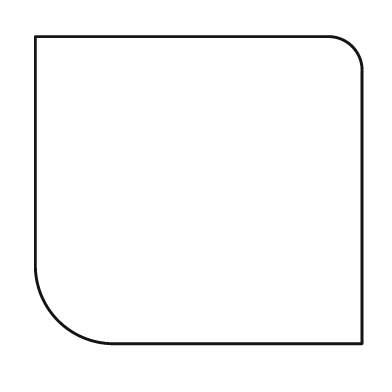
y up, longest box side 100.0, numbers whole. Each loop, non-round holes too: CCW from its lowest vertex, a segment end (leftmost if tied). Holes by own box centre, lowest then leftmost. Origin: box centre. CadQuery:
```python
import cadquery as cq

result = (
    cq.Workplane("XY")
    .moveTo(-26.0, -47.0)
    .lineTo(50.0, -47.0)
    .lineTo(50.0, 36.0)
    .threePointArc((47.0, 44.0), (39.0, 47.0))
    .lineTo(-50.0, 47.0)
    .lineTo(-50.0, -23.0)
    .threePointArc((-43.0, -40.0), (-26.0, -47.0))
    .close()
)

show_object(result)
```